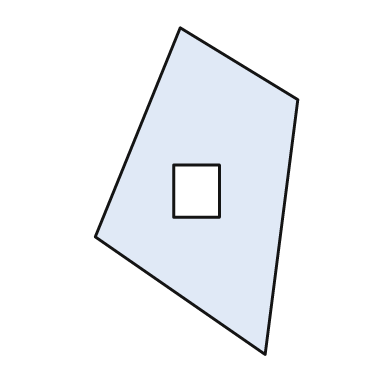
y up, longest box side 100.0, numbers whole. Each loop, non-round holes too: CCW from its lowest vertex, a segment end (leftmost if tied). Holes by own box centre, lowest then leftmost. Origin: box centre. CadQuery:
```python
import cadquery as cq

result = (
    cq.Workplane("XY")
    .moveTo(21.0, -50.0)
    .lineTo(31.0, 28.0)
    .lineTo(-5.0, 50.0)
    .lineTo(-31.0, -14.0)
    .close()
    .moveTo(-7.0, -8.0)
    .lineTo(7.0, -8.0)
    .lineTo(7.0, 8.0)
    .lineTo(-7.0, 8.0)
    .close()
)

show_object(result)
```